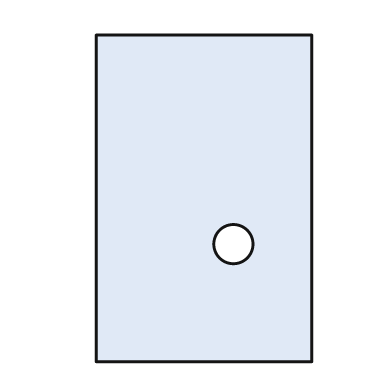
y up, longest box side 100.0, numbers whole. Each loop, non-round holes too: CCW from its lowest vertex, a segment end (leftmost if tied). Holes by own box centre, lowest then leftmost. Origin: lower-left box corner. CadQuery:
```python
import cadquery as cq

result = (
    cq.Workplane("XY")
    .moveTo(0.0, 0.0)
    .lineTo(66.0, 0.0)
    .lineTo(66.0, 100.0)
    .lineTo(0.0, 100.0)
    .close()
    .moveTo(42.0, 36.0)
    .circle(6.0)
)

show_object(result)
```